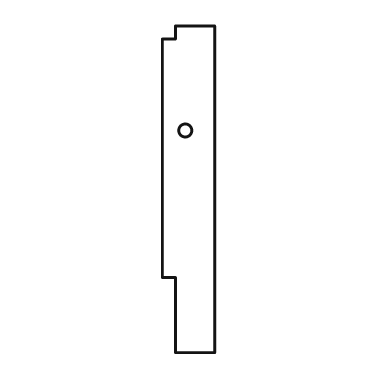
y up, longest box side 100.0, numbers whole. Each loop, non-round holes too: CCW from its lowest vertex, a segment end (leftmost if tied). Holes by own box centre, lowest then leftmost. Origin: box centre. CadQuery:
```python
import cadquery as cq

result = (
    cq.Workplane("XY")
    .moveTo(-4.0, -50.0)
    .lineTo(8.0, -50.0)
    .lineTo(8.0, 50.0)
    .lineTo(-4.0, 50.0)
    .lineTo(-4.0, 46.0)
    .lineTo(-8.0, 46.0)
    .lineTo(-8.0, -27.0)
    .lineTo(-4.0, -27.0)
    .close()
    .moveTo(-1.0, 18.0)
    .circle(2.0)
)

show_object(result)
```